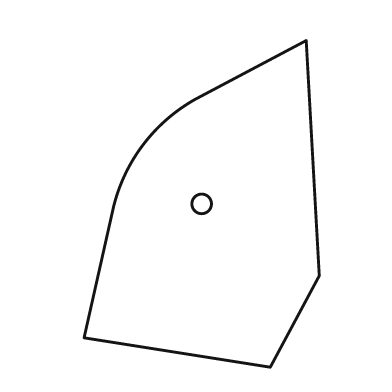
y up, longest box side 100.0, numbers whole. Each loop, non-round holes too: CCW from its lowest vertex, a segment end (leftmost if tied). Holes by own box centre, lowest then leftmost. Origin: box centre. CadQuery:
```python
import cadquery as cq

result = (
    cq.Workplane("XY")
    .moveTo(21.0, -50.0)
    .lineTo(36.0, -22.0)
    .lineTo(32.0, 50.0)
    .lineTo(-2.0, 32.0)
    .threePointArc((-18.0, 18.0), (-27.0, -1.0))
    .lineTo(-36.0, -41.0)
    .close()
    .moveTo(0.0, 0.0)
    .circle(3.0)
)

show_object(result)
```